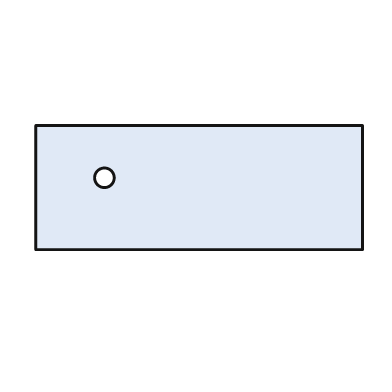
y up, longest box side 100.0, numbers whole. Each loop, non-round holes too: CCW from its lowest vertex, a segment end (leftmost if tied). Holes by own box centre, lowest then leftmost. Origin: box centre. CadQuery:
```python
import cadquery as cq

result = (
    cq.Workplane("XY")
    .moveTo(-50.0, -19.0)
    .lineTo(50.0, -19.0)
    .lineTo(50.0, 19.0)
    .lineTo(-50.0, 19.0)
    .close()
    .moveTo(-29.0, 3.0)
    .circle(3.0)
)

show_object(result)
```